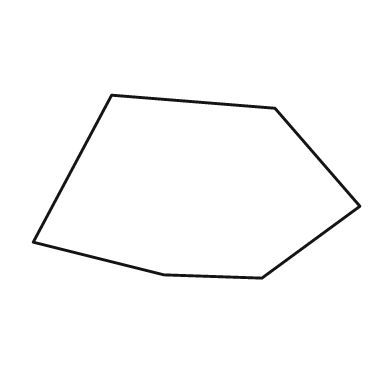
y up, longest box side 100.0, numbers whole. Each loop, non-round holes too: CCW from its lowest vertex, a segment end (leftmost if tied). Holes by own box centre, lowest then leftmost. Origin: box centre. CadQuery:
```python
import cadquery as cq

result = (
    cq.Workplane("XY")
    .moveTo(20.0, -28.0)
    .lineTo(50.0, -6.0)
    .lineTo(24.0, 24.0)
    .lineTo(-26.0, 28.0)
    .lineTo(-50.0, -17.0)
    .lineTo(-10.0, -27.0)
    .close()
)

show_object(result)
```